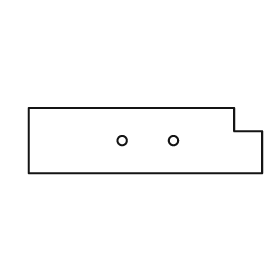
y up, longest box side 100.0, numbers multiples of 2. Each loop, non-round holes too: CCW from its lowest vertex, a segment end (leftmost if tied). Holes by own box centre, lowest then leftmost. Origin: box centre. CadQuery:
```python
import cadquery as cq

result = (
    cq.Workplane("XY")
    .moveTo(-50.0, -14.0)
    .lineTo(50.0, -14.0)
    .lineTo(50.0, 4.0)
    .lineTo(38.0, 4.0)
    .lineTo(38.0, 14.0)
    .lineTo(-50.0, 14.0)
    .close()
    .moveTo(-10.0, 0.0)
    .circle(2.0)
    .moveTo(12.0, 0.0)
    .circle(2.0)
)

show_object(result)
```